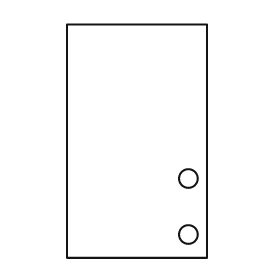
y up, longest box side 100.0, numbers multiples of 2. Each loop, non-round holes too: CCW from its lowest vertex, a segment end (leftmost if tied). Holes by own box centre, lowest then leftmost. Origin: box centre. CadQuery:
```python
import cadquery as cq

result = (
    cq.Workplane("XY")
    .moveTo(-30.0, -50.0)
    .lineTo(30.0, -50.0)
    .lineTo(30.0, 50.0)
    .lineTo(-30.0, 50.0)
    .close()
    .moveTo(22.0, -40.0)
    .circle(4.0)
    .moveTo(22.0, -16.0)
    .circle(4.0)
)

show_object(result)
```